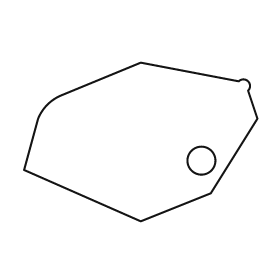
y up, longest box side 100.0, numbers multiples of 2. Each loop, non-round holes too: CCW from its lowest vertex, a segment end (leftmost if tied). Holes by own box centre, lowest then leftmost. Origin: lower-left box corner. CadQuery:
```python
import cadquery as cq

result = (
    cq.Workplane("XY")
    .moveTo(50.0, 0.0)
    .lineTo(80.0, 12.0)
    .lineTo(100.0, 44.0)
    .lineTo(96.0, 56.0)
    .threePointArc((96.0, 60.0), (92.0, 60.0))
    .lineTo(50.0, 68.0)
    .lineTo(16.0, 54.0)
    .threePointArc((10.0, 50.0), (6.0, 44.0))
    .lineTo(0.0, 22.0)
    .close()
    .moveTo(76.0, 26.0)
    .circle(6.0)
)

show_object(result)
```